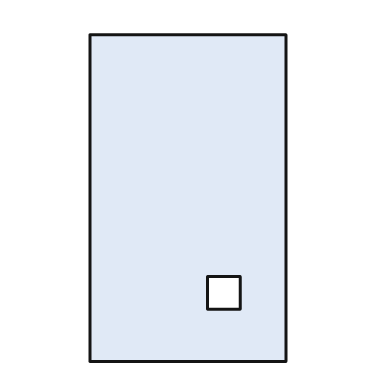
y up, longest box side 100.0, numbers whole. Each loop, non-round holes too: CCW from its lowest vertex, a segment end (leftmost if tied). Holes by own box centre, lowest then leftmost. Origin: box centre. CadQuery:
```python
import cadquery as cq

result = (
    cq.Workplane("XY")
    .moveTo(-30.0, -50.0)
    .lineTo(30.0, -50.0)
    .lineTo(30.0, 50.0)
    .lineTo(-30.0, 50.0)
    .close()
    .moveTo(6.0, -34.0)
    .lineTo(16.0, -34.0)
    .lineTo(16.0, -24.0)
    .lineTo(6.0, -24.0)
    .close()
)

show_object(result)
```